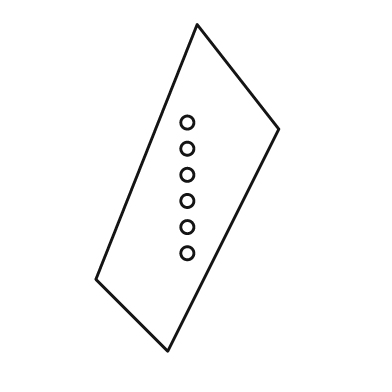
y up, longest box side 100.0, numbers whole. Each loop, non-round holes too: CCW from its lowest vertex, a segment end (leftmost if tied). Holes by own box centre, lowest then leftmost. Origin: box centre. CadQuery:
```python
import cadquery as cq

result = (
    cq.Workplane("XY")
    .moveTo(-6.0, -50.0)
    .lineTo(28.0, 18.0)
    .lineTo(3.0, 50.0)
    .lineTo(-28.0, -28.0)
    .close()
    .moveTo(0.0, -20.0)
    .circle(2.0)
    .moveTo(0.0, -12.0)
    .circle(2.0)
    .moveTo(0.0, -4.0)
    .circle(2.0)
    .moveTo(0.0, 4.0)
    .circle(2.0)
    .moveTo(0.0, 12.0)
    .circle(2.0)
    .moveTo(0.0, 20.0)
    .circle(2.0)
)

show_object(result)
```